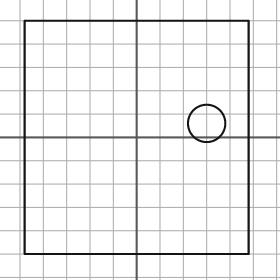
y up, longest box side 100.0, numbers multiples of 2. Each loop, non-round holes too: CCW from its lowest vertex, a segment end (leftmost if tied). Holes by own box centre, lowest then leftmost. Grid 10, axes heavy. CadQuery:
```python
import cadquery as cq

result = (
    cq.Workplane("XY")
    .moveTo(-48.0, -50.0)
    .lineTo(48.0, -50.0)
    .lineTo(48.0, 50.0)
    .lineTo(-48.0, 50.0)
    .close()
    .moveTo(30.0, 6.0)
    .circle(8.0)
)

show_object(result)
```